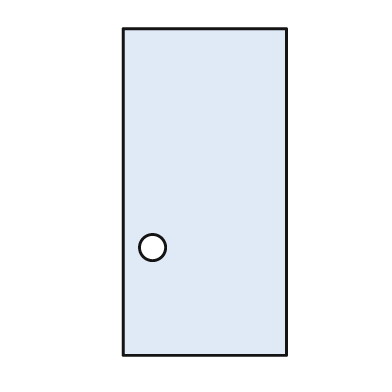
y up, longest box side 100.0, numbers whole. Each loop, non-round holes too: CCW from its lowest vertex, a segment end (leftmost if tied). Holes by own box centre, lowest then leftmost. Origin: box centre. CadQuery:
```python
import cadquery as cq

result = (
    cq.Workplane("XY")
    .moveTo(-25.0, -50.0)
    .lineTo(25.0, -50.0)
    .lineTo(25.0, 50.0)
    .lineTo(-25.0, 50.0)
    .close()
    .moveTo(-16.0, -17.0)
    .circle(4.0)
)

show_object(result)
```